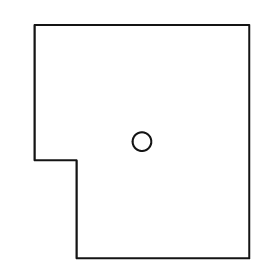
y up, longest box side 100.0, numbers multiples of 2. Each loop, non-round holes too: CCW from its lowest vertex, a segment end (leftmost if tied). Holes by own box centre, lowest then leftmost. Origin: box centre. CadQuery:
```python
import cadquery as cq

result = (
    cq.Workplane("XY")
    .moveTo(-28.0, -50.0)
    .lineTo(46.0, -50.0)
    .lineTo(46.0, 50.0)
    .lineTo(-46.0, 50.0)
    .lineTo(-46.0, -8.0)
    .lineTo(-28.0, -8.0)
    .close()
    .moveTo(0.0, 0.0)
    .circle(4.0)
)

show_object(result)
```